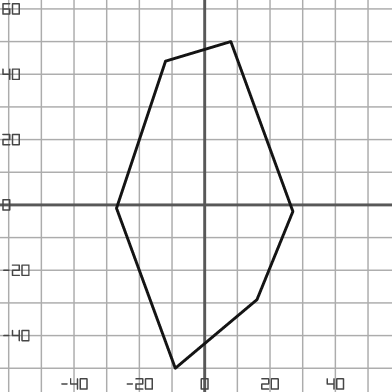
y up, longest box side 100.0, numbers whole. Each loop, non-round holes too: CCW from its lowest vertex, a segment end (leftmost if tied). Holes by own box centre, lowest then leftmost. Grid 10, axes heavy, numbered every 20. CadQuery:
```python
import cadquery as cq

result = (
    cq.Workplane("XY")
    .moveTo(-9.0, -50.0)
    .lineTo(16.0, -29.0)
    .lineTo(27.0, -2.0)
    .lineTo(8.0, 50.0)
    .lineTo(-12.0, 44.0)
    .lineTo(-27.0, -1.0)
    .close()
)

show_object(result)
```